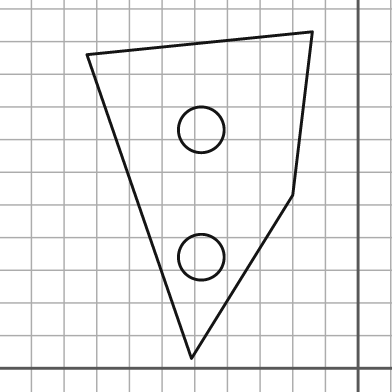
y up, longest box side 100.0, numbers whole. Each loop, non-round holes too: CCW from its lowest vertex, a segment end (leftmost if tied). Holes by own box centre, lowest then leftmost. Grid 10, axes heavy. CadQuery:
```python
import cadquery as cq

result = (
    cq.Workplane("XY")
    .moveTo(-51.0, 3.0)
    .lineTo(-20.0, 53.0)
    .lineTo(-14.0, 103.0)
    .lineTo(-83.0, 96.0)
    .close()
    .moveTo(-48.0, 34.0)
    .circle(7.0)
    .moveTo(-48.0, 73.0)
    .circle(7.0)
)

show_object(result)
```